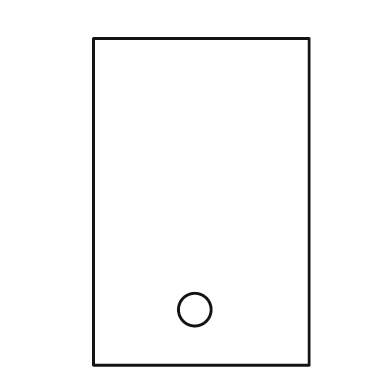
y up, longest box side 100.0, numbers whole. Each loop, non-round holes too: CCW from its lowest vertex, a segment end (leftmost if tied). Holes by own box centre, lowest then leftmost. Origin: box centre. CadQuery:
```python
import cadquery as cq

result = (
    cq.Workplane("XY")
    .moveTo(-33.0, -50.0)
    .lineTo(33.0, -50.0)
    .lineTo(33.0, 50.0)
    .lineTo(-33.0, 50.0)
    .close()
    .moveTo(-2.0, -33.0)
    .circle(5.0)
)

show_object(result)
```